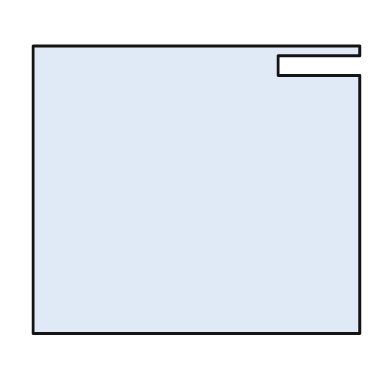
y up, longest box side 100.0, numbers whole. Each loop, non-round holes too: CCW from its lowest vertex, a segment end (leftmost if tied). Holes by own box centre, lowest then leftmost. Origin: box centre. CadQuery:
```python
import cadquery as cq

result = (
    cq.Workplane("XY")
    .moveTo(-50.0, -44.0)
    .lineTo(50.0, -44.0)
    .lineTo(50.0, 35.0)
    .lineTo(25.0, 35.0)
    .lineTo(25.0, 41.0)
    .lineTo(50.0, 41.0)
    .lineTo(50.0, 44.0)
    .lineTo(-50.0, 44.0)
    .close()
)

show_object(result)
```